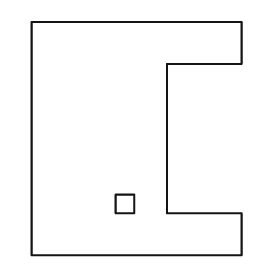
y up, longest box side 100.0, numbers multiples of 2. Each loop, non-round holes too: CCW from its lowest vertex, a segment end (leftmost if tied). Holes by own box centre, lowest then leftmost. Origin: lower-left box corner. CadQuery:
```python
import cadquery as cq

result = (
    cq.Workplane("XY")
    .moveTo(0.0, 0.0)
    .lineTo(90.0, 0.0)
    .lineTo(90.0, 18.0)
    .lineTo(58.0, 18.0)
    .lineTo(58.0, 82.0)
    .lineTo(90.0, 82.0)
    .lineTo(90.0, 100.0)
    .lineTo(0.0, 100.0)
    .close()
    .moveTo(36.0, 18.0)
    .lineTo(44.0, 18.0)
    .lineTo(44.0, 26.0)
    .lineTo(36.0, 26.0)
    .close()
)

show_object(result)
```